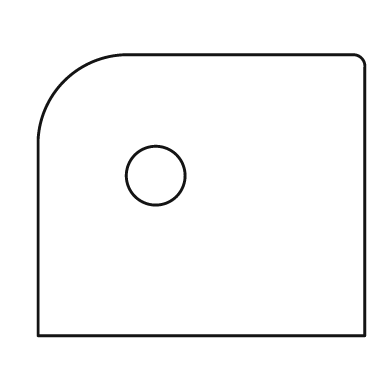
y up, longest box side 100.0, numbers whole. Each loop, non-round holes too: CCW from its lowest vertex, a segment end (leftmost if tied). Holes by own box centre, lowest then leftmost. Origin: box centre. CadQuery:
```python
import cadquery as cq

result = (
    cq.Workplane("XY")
    .moveTo(-50.0, -43.0)
    .lineTo(50.0, -43.0)
    .lineTo(50.0, 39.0)
    .threePointArc((49.0, 42.0), (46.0, 43.0))
    .lineTo(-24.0, 43.0)
    .threePointArc((-42.0, 35.0), (-50.0, 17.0))
    .close()
    .moveTo(-14.0, 6.0)
    .circle(9.0)
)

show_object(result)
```